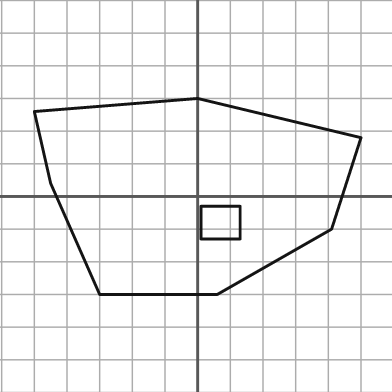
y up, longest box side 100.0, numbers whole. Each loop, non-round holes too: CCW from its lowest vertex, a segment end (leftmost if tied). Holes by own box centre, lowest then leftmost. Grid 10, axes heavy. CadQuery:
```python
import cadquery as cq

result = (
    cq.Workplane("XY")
    .moveTo(-30.0, -30.0)
    .lineTo(6.0, -30.0)
    .lineTo(41.0, -10.0)
    .lineTo(50.0, 18.0)
    .lineTo(0.0, 30.0)
    .lineTo(-50.0, 26.0)
    .lineTo(-45.0, 4.0)
    .close()
    .moveTo(1.0, -13.0)
    .lineTo(13.0, -13.0)
    .lineTo(13.0, -3.0)
    .lineTo(1.0, -3.0)
    .close()
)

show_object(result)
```